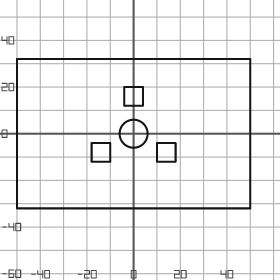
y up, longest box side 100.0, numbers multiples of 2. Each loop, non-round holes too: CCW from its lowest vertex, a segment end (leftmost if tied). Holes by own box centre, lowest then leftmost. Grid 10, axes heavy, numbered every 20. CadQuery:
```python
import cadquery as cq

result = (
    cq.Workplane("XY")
    .moveTo(-50.0, -32.0)
    .lineTo(50.0, -32.0)
    .lineTo(50.0, 32.0)
    .lineTo(-50.0, 32.0)
    .close()
    .moveTo(-18.0, -12.0)
    .lineTo(-10.0, -12.0)
    .lineTo(-10.0, -4.0)
    .lineTo(-18.0, -4.0)
    .close()
    .moveTo(10.0, -12.0)
    .lineTo(18.0, -12.0)
    .lineTo(18.0, -4.0)
    .lineTo(10.0, -4.0)
    .close()
    .moveTo(0.0, 0.0)
    .circle(6.0)
    .moveTo(-4.0, 12.0)
    .lineTo(4.0, 12.0)
    .lineTo(4.0, 20.0)
    .lineTo(-4.0, 20.0)
    .close()
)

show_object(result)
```